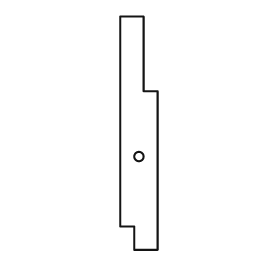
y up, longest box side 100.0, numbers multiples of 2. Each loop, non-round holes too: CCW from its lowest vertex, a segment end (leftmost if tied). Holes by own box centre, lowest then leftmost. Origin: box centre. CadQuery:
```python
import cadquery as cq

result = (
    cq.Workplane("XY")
    .moveTo(-2.0, -50.0)
    .lineTo(8.0, -50.0)
    .lineTo(8.0, 18.0)
    .lineTo(2.0, 18.0)
    .lineTo(2.0, 50.0)
    .lineTo(-8.0, 50.0)
    .lineTo(-8.0, -40.0)
    .lineTo(-2.0, -40.0)
    .close()
    .moveTo(0.0, -10.0)
    .circle(2.0)
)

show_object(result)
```